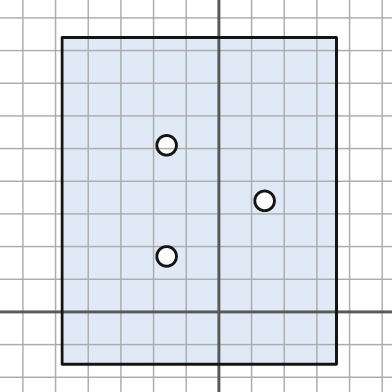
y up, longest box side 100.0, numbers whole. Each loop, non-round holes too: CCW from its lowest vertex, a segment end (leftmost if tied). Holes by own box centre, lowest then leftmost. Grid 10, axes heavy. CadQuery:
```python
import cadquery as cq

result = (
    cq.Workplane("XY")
    .moveTo(-48.0, -16.0)
    .lineTo(36.0, -16.0)
    .lineTo(36.0, 84.0)
    .lineTo(-48.0, 84.0)
    .close()
    .moveTo(-16.0, 17.0)
    .circle(3.0)
    .moveTo(14.0, 34.0)
    .circle(3.0)
    .moveTo(-16.0, 51.0)
    .circle(3.0)
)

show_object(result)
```